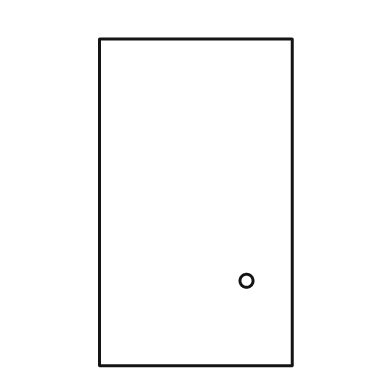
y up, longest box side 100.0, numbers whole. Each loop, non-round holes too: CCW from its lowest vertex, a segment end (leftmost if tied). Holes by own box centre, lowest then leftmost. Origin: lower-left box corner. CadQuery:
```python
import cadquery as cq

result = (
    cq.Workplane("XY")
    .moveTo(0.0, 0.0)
    .lineTo(59.0, 0.0)
    .lineTo(59.0, 100.0)
    .lineTo(0.0, 100.0)
    .close()
    .moveTo(45.0, 26.0)
    .circle(2.0)
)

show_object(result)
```